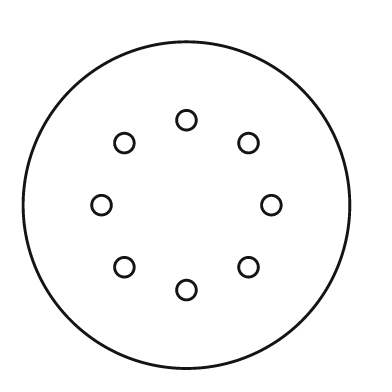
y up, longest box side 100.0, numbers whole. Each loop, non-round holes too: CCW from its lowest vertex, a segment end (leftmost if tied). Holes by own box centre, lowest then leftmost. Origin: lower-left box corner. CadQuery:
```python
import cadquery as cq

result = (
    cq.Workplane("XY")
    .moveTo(50.0, 50.0)
    .circle(50.0)
    .moveTo(50.0, 24.0)
    .circle(3.0)
    .moveTo(31.0, 31.0)
    .circle(3.0)
    .moveTo(69.0, 31.0)
    .circle(3.0)
    .moveTo(24.0, 50.0)
    .circle(3.0)
    .moveTo(76.0, 50.0)
    .circle(3.0)
    .moveTo(31.0, 69.0)
    .circle(3.0)
    .moveTo(69.0, 69.0)
    .circle(3.0)
    .moveTo(50.0, 76.0)
    .circle(3.0)
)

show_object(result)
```